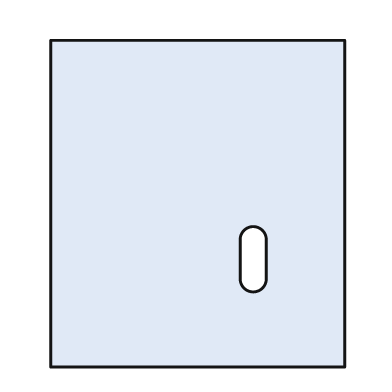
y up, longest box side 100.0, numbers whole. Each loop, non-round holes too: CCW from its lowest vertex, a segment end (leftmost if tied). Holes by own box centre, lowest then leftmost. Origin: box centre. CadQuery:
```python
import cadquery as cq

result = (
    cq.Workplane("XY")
    .moveTo(-45.0, -50.0)
    .lineTo(45.0, -50.0)
    .lineTo(45.0, 50.0)
    .lineTo(-45.0, 50.0)
    .close()
    .moveTo(13.0, -23.0)
    .threePointArc((17.0, -27.0), (21.0, -23.0))
    .lineTo(21.0, -11.0)
    .threePointArc((17.0, -7.0), (13.0, -11.0))
    .close()
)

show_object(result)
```